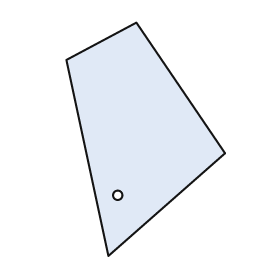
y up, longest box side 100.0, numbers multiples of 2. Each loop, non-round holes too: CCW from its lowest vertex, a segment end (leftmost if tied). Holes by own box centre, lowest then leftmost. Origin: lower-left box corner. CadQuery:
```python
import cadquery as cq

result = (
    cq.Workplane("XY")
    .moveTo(18.0, 0.0)
    .lineTo(68.0, 44.0)
    .lineTo(30.0, 100.0)
    .lineTo(0.0, 84.0)
    .close()
    .moveTo(22.0, 26.0)
    .circle(2.0)
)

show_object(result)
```